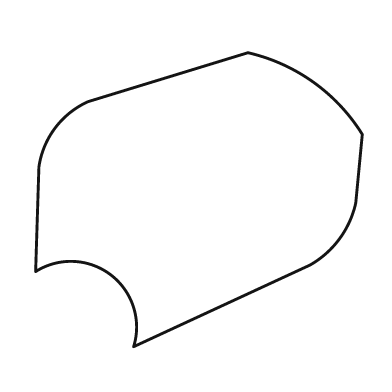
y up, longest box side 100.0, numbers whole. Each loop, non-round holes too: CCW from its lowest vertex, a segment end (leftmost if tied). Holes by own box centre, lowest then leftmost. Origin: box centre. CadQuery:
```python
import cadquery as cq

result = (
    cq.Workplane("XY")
    .moveTo(-20.0, -45.0)
    .lineTo(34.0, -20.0)
    .threePointArc((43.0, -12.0), (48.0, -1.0))
    .lineTo(50.0, 20.0)
    .threePointArc((35.0, 36.0), (15.0, 45.0))
    .lineTo(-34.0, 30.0)
    .threePointArc((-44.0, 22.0), (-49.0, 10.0))
    .lineTo(-50.0, -22.0)
    .threePointArc((-27.0, -23.0), (-20.0, -45.0))
    .close()
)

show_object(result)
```